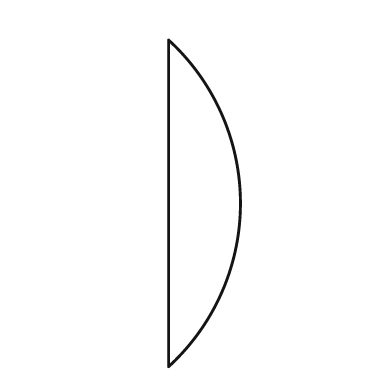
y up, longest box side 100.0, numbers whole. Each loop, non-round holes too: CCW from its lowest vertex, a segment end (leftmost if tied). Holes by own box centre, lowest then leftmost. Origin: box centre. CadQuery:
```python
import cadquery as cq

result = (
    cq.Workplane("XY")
    .moveTo(-11.0, -50.0)
    .threePointArc((11.0, 0.0), (-11.0, 50.0))
    .close()
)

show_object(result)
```